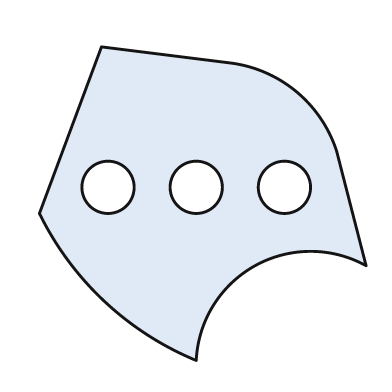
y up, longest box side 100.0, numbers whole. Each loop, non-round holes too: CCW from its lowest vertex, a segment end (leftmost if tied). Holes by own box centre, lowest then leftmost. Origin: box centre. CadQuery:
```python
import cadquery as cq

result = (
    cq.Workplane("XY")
    .moveTo(-2.0, -48.0)
    .threePointArc((16.0, -19.0), (50.0, -19.0))
    .lineTo(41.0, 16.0)
    .threePointArc((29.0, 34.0), (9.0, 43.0))
    .lineTo(-31.0, 48.0)
    .lineTo(-50.0, -3.0)
    .threePointArc((-30.0, -30.0), (-2.0, -48.0))
    .close()
    .moveTo(-29.0, 5.0)
    .circle(8.0)
    .moveTo(-2.0, 5.0)
    .circle(8.0)
    .moveTo(25.0, 5.0)
    .circle(8.0)
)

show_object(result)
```